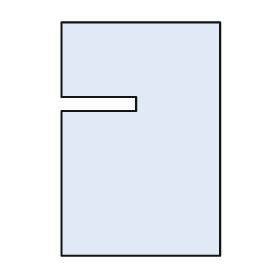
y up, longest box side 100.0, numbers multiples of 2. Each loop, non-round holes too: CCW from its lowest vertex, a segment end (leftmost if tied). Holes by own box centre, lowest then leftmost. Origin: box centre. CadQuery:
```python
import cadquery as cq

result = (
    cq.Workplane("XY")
    .moveTo(-34.0, -50.0)
    .lineTo(34.0, -50.0)
    .lineTo(34.0, 50.0)
    .lineTo(-34.0, 50.0)
    .lineTo(-34.0, 18.0)
    .lineTo(-2.0, 18.0)
    .lineTo(-2.0, 12.0)
    .lineTo(-34.0, 12.0)
    .close()
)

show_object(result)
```